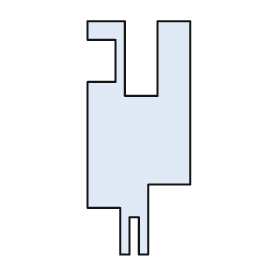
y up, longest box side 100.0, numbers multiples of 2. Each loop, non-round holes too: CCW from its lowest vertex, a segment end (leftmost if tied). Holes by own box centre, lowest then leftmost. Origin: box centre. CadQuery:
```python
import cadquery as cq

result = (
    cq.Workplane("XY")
    .moveTo(-8.0, -50.0)
    .lineTo(-4.0, -50.0)
    .lineTo(-4.0, -34.0)
    .lineTo(0.0, -34.0)
    .lineTo(0.0, -50.0)
    .lineTo(4.0, -50.0)
    .lineTo(4.0, -20.0)
    .lineTo(22.0, -20.0)
    .lineTo(22.0, 50.0)
    .lineTo(8.0, 50.0)
    .lineTo(8.0, 18.0)
    .lineTo(-6.0, 18.0)
    .lineTo(-6.0, 50.0)
    .lineTo(-22.0, 50.0)
    .lineTo(-22.0, 42.0)
    .lineTo(-10.0, 42.0)
    .lineTo(-10.0, 24.0)
    .lineTo(-22.0, 24.0)
    .lineTo(-22.0, -30.0)
    .lineTo(-8.0, -30.0)
    .close()
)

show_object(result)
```